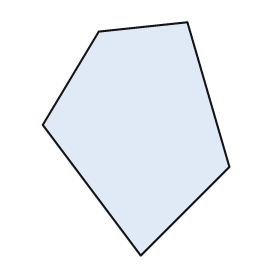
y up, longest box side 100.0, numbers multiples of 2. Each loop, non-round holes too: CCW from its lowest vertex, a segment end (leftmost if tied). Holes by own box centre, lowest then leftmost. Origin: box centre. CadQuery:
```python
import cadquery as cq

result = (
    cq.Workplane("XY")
    .moveTo(2.0, -50.0)
    .lineTo(40.0, -12.0)
    .lineTo(22.0, 50.0)
    .lineTo(-16.0, 46.0)
    .lineTo(-40.0, 6.0)
    .close()
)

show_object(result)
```